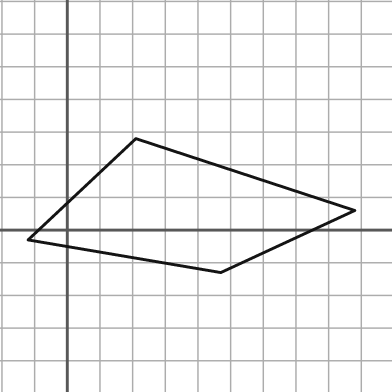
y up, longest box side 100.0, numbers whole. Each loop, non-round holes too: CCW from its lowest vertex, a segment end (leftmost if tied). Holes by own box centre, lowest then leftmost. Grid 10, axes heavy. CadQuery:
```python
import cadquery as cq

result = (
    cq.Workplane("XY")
    .moveTo(47.0, -13.0)
    .lineTo(88.0, 6.0)
    .lineTo(21.0, 28.0)
    .lineTo(-12.0, -3.0)
    .close()
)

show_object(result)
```